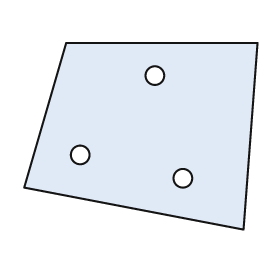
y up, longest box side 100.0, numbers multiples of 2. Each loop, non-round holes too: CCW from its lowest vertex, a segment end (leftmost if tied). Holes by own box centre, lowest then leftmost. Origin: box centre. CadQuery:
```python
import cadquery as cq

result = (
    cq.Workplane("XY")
    .moveTo(44.0, -40.0)
    .lineTo(50.0, 40.0)
    .lineTo(-32.0, 40.0)
    .lineTo(-50.0, -22.0)
    .close()
    .moveTo(18.0, -18.0)
    .circle(4.0)
    .moveTo(-26.0, -8.0)
    .circle(4.0)
    .moveTo(6.0, 26.0)
    .circle(4.0)
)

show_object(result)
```